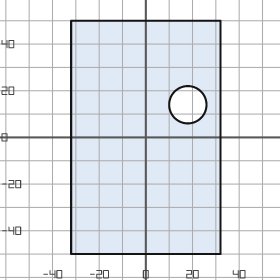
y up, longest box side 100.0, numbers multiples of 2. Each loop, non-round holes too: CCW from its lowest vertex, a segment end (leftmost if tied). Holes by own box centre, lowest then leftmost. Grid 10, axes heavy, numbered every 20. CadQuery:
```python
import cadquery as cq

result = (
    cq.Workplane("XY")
    .moveTo(-32.0, -50.0)
    .lineTo(32.0, -50.0)
    .lineTo(32.0, 50.0)
    .lineTo(-32.0, 50.0)
    .close()
    .moveTo(18.0, 14.0)
    .circle(8.0)
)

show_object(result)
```